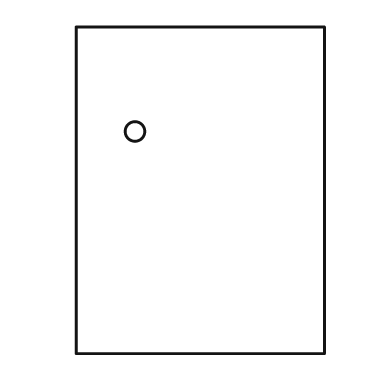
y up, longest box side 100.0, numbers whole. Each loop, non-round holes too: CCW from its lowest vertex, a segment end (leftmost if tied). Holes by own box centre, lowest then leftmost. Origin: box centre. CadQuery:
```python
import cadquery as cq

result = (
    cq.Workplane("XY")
    .moveTo(-38.0, -50.0)
    .lineTo(38.0, -50.0)
    .lineTo(38.0, 50.0)
    .lineTo(-38.0, 50.0)
    .close()
    .moveTo(-20.0, 18.0)
    .circle(3.0)
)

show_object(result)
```